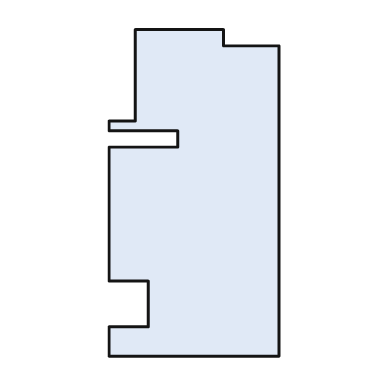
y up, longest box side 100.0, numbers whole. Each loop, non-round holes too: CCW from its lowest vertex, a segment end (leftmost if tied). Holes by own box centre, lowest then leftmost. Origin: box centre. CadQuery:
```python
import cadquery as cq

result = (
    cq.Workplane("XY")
    .moveTo(-26.0, -50.0)
    .lineTo(26.0, -50.0)
    .lineTo(26.0, 45.0)
    .lineTo(9.0, 45.0)
    .lineTo(9.0, 50.0)
    .lineTo(-18.0, 50.0)
    .lineTo(-18.0, 22.0)
    .lineTo(-26.0, 22.0)
    .lineTo(-26.0, 19.0)
    .lineTo(-5.0, 19.0)
    .lineTo(-5.0, 14.0)
    .lineTo(-26.0, 14.0)
    .lineTo(-26.0, -27.0)
    .lineTo(-14.0, -27.0)
    .lineTo(-14.0, -41.0)
    .lineTo(-26.0, -41.0)
    .close()
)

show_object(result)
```